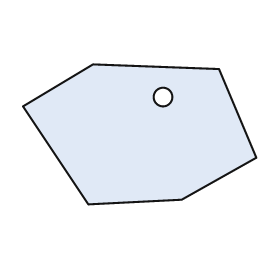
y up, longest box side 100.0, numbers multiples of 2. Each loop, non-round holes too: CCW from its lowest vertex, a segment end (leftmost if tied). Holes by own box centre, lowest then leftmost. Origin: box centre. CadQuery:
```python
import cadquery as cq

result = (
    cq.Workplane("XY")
    .moveTo(-22.0, -30.0)
    .lineTo(18.0, -28.0)
    .lineTo(50.0, -10.0)
    .lineTo(34.0, 28.0)
    .lineTo(-20.0, 30.0)
    .lineTo(-50.0, 12.0)
    .close()
    .moveTo(10.0, 16.0)
    .circle(4.0)
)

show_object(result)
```